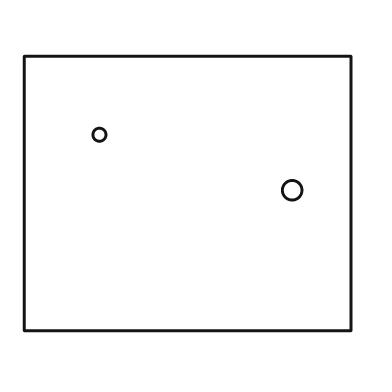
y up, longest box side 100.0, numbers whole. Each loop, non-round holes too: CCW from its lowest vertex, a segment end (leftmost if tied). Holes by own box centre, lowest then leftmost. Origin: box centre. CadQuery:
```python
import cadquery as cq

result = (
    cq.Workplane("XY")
    .moveTo(-50.0, -42.0)
    .lineTo(50.0, -42.0)
    .lineTo(50.0, 42.0)
    .lineTo(-50.0, 42.0)
    .close()
    .moveTo(32.0, 1.0)
    .circle(3.0)
    .moveTo(-27.0, 18.0)
    .circle(2.0)
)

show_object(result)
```